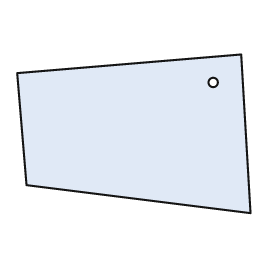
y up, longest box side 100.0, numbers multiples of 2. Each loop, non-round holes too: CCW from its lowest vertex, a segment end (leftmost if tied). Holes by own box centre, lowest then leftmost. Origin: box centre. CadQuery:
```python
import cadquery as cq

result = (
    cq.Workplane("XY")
    .moveTo(50.0, -34.0)
    .lineTo(46.0, 34.0)
    .lineTo(-50.0, 26.0)
    .lineTo(-46.0, -22.0)
    .close()
    .moveTo(34.0, 22.0)
    .circle(2.0)
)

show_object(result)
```